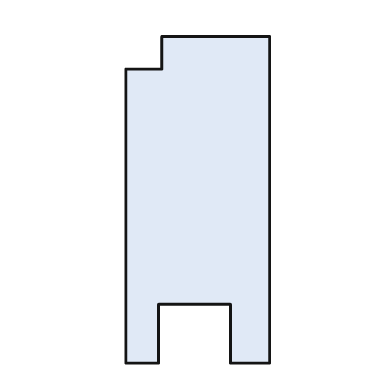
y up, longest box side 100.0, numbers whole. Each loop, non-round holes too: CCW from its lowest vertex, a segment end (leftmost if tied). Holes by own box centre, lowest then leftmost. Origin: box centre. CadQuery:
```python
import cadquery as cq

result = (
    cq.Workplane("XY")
    .moveTo(-22.0, -50.0)
    .lineTo(-12.0, -50.0)
    .lineTo(-12.0, -32.0)
    .lineTo(10.0, -32.0)
    .lineTo(10.0, -50.0)
    .lineTo(22.0, -50.0)
    .lineTo(22.0, 50.0)
    .lineTo(-11.0, 50.0)
    .lineTo(-11.0, 40.0)
    .lineTo(-22.0, 40.0)
    .close()
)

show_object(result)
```